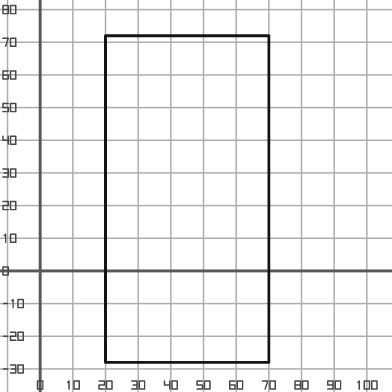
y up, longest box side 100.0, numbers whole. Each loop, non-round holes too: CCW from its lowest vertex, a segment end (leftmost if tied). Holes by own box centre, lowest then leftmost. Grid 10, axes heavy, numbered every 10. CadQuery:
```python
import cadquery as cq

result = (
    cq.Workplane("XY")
    .moveTo(20.0, -28.0)
    .lineTo(70.0, -28.0)
    .lineTo(70.0, 72.0)
    .lineTo(20.0, 72.0)
    .close()
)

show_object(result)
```